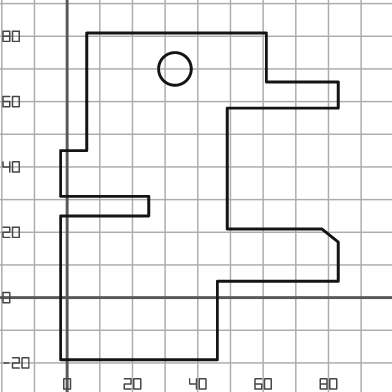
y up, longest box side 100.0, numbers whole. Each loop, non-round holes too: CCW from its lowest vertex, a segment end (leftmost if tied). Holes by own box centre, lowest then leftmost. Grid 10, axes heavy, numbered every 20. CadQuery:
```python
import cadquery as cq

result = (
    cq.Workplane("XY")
    .moveTo(-2.0, -19.0)
    .lineTo(46.0, -19.0)
    .lineTo(46.0, 5.0)
    .lineTo(83.0, 5.0)
    .lineTo(83.0, 17.0)
    .lineTo(78.0, 21.0)
    .lineTo(49.0, 21.0)
    .lineTo(49.0, 58.0)
    .lineTo(83.0, 58.0)
    .lineTo(83.0, 66.0)
    .lineTo(61.0, 66.0)
    .lineTo(61.0, 81.0)
    .lineTo(6.0, 81.0)
    .lineTo(6.0, 45.0)
    .lineTo(-2.0, 45.0)
    .lineTo(-2.0, 31.0)
    .lineTo(25.0, 31.0)
    .lineTo(25.0, 25.0)
    .lineTo(-2.0, 25.0)
    .close()
    .moveTo(33.0, 70.0)
    .circle(5.0)
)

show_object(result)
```